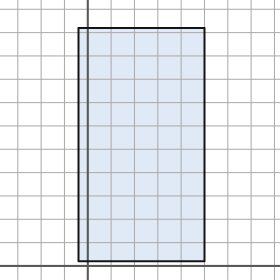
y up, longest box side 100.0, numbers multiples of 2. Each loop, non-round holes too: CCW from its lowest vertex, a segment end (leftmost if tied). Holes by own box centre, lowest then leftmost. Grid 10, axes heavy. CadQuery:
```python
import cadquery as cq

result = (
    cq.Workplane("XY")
    .moveTo(-4.0, 2.0)
    .lineTo(50.0, 2.0)
    .lineTo(50.0, 102.0)
    .lineTo(-4.0, 102.0)
    .close()
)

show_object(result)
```